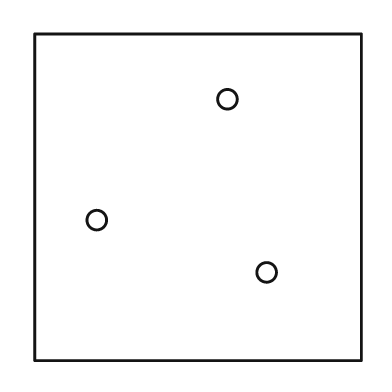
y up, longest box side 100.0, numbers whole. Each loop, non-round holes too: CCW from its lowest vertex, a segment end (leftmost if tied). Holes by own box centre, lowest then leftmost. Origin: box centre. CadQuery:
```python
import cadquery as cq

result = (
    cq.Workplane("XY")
    .moveTo(-50.0, -50.0)
    .lineTo(50.0, -50.0)
    .lineTo(50.0, 50.0)
    .lineTo(-50.0, 50.0)
    .close()
    .moveTo(21.0, -23.0)
    .circle(3.0)
    .moveTo(-31.0, -7.0)
    .circle(3.0)
    .moveTo(9.0, 30.0)
    .circle(3.0)
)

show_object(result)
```